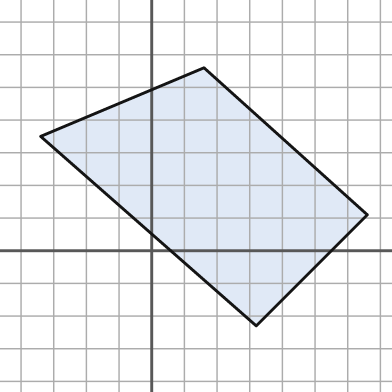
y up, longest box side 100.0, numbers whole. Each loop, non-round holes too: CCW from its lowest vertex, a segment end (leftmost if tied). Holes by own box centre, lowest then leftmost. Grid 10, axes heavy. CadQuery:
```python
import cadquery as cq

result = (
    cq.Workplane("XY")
    .moveTo(32.0, -23.0)
    .lineTo(66.0, 11.0)
    .lineTo(16.0, 56.0)
    .lineTo(-34.0, 35.0)
    .close()
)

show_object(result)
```